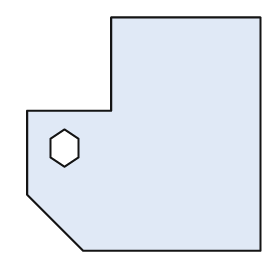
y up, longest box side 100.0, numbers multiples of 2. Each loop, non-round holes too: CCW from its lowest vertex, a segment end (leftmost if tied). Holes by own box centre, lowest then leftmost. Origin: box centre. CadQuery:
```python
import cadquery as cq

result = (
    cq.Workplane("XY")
    .moveTo(-26.0, -50.0)
    .lineTo(50.0, -50.0)
    .lineTo(50.0, 50.0)
    .lineTo(-14.0, 50.0)
    .lineTo(-14.0, 10.0)
    .lineTo(-50.0, 10.0)
    .lineTo(-50.0, -26.0)
    .close()
    .moveTo(-34.0, -14.0)
    .lineTo(-28.0, -10.0)
    .lineTo(-28.0, -2.0)
    .lineTo(-34.0, 2.0)
    .lineTo(-40.0, -2.0)
    .lineTo(-40.0, -10.0)
    .close()
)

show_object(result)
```